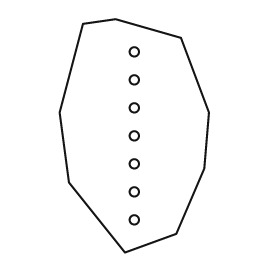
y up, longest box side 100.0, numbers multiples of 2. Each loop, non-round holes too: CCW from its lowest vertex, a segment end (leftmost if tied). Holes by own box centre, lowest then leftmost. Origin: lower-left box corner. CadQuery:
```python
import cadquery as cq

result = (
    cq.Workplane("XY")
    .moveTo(28.0, 0.0)
    .lineTo(50.0, 8.0)
    .lineTo(62.0, 36.0)
    .lineTo(64.0, 60.0)
    .lineTo(52.0, 92.0)
    .lineTo(24.0, 100.0)
    .lineTo(10.0, 98.0)
    .lineTo(0.0, 60.0)
    .lineTo(4.0, 30.0)
    .close()
    .moveTo(32.0, 14.0)
    .circle(2.0)
    .moveTo(32.0, 26.0)
    .circle(2.0)
    .moveTo(32.0, 38.0)
    .circle(2.0)
    .moveTo(32.0, 50.0)
    .circle(2.0)
    .moveTo(32.0, 62.0)
    .circle(2.0)
    .moveTo(32.0, 74.0)
    .circle(2.0)
    .moveTo(32.0, 86.0)
    .circle(2.0)
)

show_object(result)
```